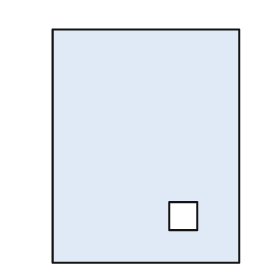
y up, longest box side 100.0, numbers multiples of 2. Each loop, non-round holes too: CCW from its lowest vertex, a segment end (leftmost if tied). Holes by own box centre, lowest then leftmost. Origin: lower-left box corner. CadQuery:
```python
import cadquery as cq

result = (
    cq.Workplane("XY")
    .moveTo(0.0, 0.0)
    .lineTo(80.0, 0.0)
    .lineTo(80.0, 100.0)
    .lineTo(0.0, 100.0)
    .close()
    .moveTo(50.0, 14.0)
    .lineTo(62.0, 14.0)
    .lineTo(62.0, 26.0)
    .lineTo(50.0, 26.0)
    .close()
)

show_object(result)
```